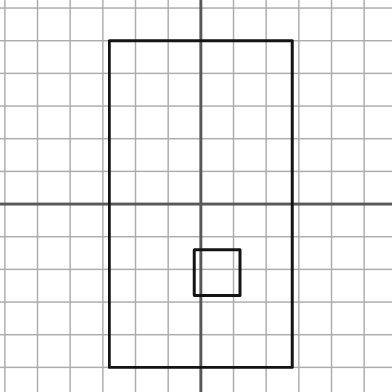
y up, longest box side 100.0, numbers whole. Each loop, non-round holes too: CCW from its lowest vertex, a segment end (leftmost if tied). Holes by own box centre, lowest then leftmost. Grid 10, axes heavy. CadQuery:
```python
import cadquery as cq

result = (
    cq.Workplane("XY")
    .moveTo(-28.0, -50.0)
    .lineTo(28.0, -50.0)
    .lineTo(28.0, 50.0)
    .lineTo(-28.0, 50.0)
    .close()
    .moveTo(-2.0, -28.0)
    .lineTo(12.0, -28.0)
    .lineTo(12.0, -14.0)
    .lineTo(-2.0, -14.0)
    .close()
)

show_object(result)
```